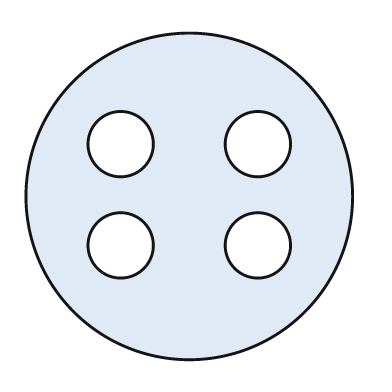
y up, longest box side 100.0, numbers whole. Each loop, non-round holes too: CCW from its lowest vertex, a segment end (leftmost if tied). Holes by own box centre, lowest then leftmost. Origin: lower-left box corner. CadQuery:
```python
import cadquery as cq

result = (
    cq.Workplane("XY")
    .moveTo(50.0, 50.0)
    .circle(50.0)
    .moveTo(29.0, 35.0)
    .circle(10.0)
    .moveTo(71.0, 35.0)
    .circle(10.0)
    .moveTo(29.0, 66.0)
    .circle(10.0)
    .moveTo(71.0, 66.0)
    .circle(10.0)
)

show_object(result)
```